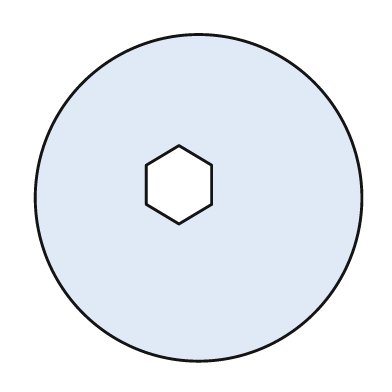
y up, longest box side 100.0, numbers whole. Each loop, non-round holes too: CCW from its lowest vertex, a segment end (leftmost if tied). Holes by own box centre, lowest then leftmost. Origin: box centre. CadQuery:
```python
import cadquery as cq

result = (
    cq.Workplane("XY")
    .moveTo(0.0, 0.0)
    .circle(50.0)
    .moveTo(-6.0, -8.0)
    .lineTo(4.0, -2.0)
    .lineTo(4.0, 10.0)
    .lineTo(-6.0, 16.0)
    .lineTo(-16.0, 10.0)
    .lineTo(-16.0, -2.0)
    .close()
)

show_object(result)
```